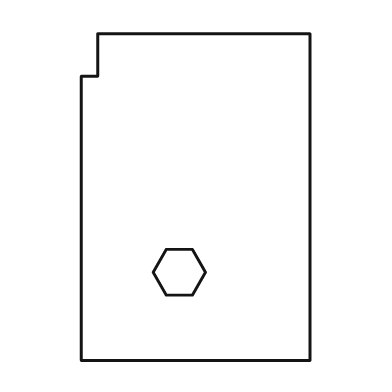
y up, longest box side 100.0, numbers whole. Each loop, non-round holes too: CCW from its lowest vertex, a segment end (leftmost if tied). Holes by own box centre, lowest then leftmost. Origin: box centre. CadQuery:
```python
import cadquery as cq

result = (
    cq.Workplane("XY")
    .moveTo(-35.0, -50.0)
    .lineTo(35.0, -50.0)
    .lineTo(35.0, 50.0)
    .lineTo(-30.0, 50.0)
    .lineTo(-30.0, 37.0)
    .lineTo(-35.0, 37.0)
    .close()
    .moveTo(-9.0, -30.0)
    .lineTo(-1.0, -30.0)
    .lineTo(3.0, -23.0)
    .lineTo(-1.0, -16.0)
    .lineTo(-9.0, -16.0)
    .lineTo(-13.0, -23.0)
    .close()
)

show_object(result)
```